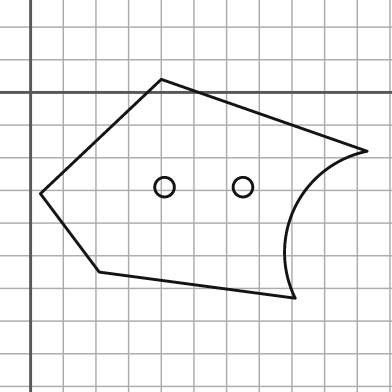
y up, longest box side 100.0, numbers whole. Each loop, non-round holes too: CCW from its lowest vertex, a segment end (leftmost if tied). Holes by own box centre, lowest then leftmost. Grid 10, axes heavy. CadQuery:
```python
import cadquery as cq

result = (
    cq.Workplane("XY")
    .moveTo(81.0, -63.0)
    .threePointArc((81.0, -35.0), (103.0, -18.0))
    .lineTo(40.0, 4.0)
    .lineTo(3.0, -31.0)
    .lineTo(21.0, -55.0)
    .close()
    .moveTo(41.0, -29.0)
    .circle(3.0)
    .moveTo(65.0, -29.0)
    .circle(3.0)
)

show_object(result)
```